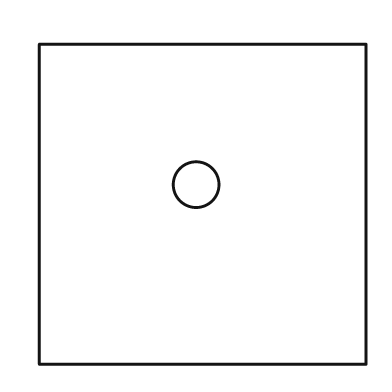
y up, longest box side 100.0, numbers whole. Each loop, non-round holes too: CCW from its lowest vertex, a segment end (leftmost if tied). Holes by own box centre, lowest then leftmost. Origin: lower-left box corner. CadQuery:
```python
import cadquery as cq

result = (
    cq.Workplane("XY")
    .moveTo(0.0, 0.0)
    .lineTo(100.0, 0.0)
    .lineTo(100.0, 98.0)
    .lineTo(0.0, 98.0)
    .close()
    .moveTo(48.0, 55.0)
    .circle(7.0)
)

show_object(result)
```